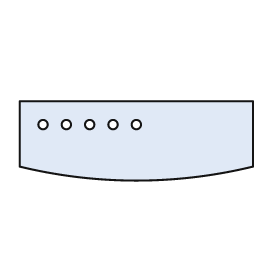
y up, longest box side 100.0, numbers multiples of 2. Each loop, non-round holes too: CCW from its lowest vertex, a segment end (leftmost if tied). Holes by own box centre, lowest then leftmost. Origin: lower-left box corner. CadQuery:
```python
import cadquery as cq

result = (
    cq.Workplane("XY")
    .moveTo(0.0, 6.0)
    .threePointArc((50.0, 0.0), (100.0, 6.0))
    .lineTo(100.0, 34.0)
    .lineTo(0.0, 34.0)
    .close()
    .moveTo(10.0, 24.0)
    .circle(2.0)
    .moveTo(20.0, 24.0)
    .circle(2.0)
    .moveTo(30.0, 24.0)
    .circle(2.0)
    .moveTo(40.0, 24.0)
    .circle(2.0)
    .moveTo(50.0, 24.0)
    .circle(2.0)
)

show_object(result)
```